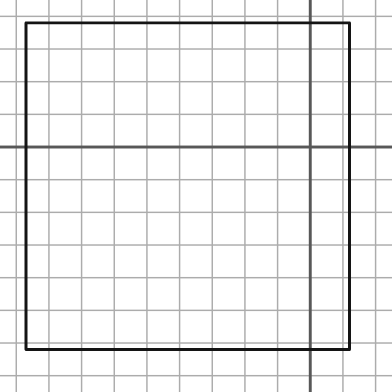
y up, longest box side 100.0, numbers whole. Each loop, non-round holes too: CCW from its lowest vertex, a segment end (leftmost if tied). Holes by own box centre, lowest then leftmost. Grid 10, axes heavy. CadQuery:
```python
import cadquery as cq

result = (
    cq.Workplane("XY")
    .moveTo(-87.0, -62.0)
    .lineTo(12.0, -62.0)
    .lineTo(12.0, 38.0)
    .lineTo(-87.0, 38.0)
    .close()
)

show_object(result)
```